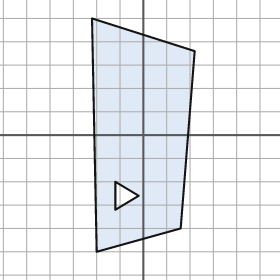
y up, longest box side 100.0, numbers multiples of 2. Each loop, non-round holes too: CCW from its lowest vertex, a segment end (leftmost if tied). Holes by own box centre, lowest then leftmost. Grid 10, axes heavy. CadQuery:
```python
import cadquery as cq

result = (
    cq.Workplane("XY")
    .moveTo(-20.0, -50.0)
    .lineTo(16.0, -40.0)
    .lineTo(22.0, 36.0)
    .lineTo(-22.0, 50.0)
    .close()
    .moveTo(-12.0, -32.0)
    .lineTo(-2.0, -26.0)
    .lineTo(-12.0, -20.0)
    .close()
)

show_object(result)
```